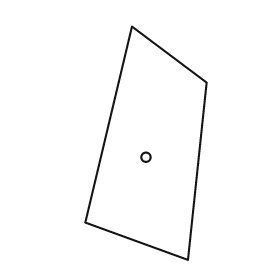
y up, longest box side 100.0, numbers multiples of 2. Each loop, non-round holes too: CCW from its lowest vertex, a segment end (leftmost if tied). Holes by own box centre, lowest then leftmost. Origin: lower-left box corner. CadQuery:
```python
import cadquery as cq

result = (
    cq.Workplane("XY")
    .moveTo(44.0, 0.0)
    .lineTo(52.0, 76.0)
    .lineTo(20.0, 100.0)
    .lineTo(0.0, 16.0)
    .close()
    .moveTo(26.0, 44.0)
    .circle(2.0)
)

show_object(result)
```